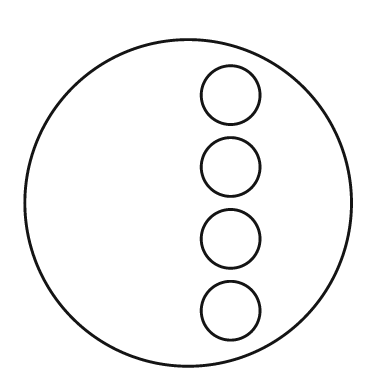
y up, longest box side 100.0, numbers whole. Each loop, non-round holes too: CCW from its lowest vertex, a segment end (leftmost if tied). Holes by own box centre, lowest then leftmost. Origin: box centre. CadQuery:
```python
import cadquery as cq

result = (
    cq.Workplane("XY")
    .moveTo(0.0, 0.0)
    .circle(50.0)
    .moveTo(13.0, -33.0)
    .circle(9.0)
    .moveTo(13.0, -11.0)
    .circle(9.0)
    .moveTo(13.0, 11.0)
    .circle(9.0)
    .moveTo(13.0, 33.0)
    .circle(9.0)
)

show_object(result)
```